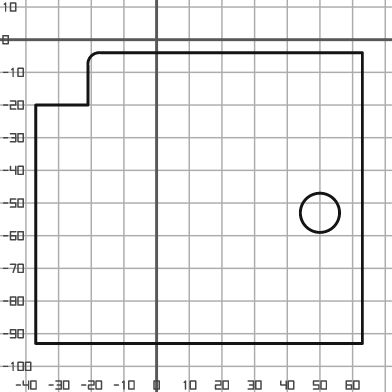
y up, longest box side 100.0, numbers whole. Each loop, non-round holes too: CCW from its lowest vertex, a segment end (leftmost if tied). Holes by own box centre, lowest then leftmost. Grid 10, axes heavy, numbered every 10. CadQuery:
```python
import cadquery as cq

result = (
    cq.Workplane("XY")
    .moveTo(-37.0, -93.0)
    .lineTo(63.0, -93.0)
    .lineTo(63.0, -4.0)
    .lineTo(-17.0, -4.0)
    .threePointArc((-20.0, -5.0), (-21.0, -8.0))
    .lineTo(-21.0, -20.0)
    .lineTo(-37.0, -20.0)
    .close()
    .moveTo(50.0, -53.0)
    .circle(6.0)
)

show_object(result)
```